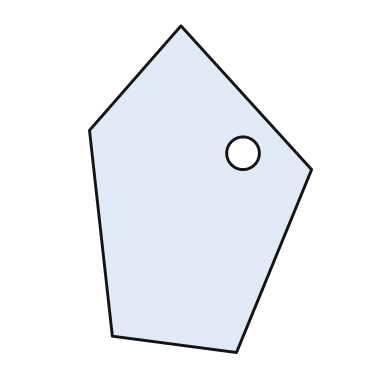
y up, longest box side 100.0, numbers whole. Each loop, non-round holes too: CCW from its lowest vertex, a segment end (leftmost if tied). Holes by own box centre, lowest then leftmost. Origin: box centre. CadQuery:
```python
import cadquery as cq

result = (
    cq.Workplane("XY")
    .moveTo(11.0, -50.0)
    .lineTo(34.0, 6.0)
    .lineTo(-6.0, 50.0)
    .lineTo(-34.0, 18.0)
    .lineTo(-27.0, -45.0)
    .close()
    .moveTo(13.0, 11.0)
    .circle(5.0)
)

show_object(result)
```